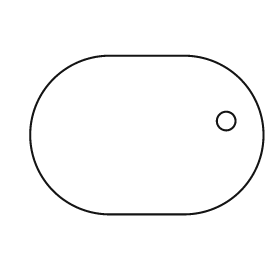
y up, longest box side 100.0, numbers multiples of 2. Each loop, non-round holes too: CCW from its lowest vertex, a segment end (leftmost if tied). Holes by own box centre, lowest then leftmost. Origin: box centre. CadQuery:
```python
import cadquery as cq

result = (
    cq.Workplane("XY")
    .moveTo(-16.0, -34.0)
    .lineTo(16.0, -34.0)
    .threePointArc((50.0, 0.0), (16.0, 34.0))
    .lineTo(-16.0, 34.0)
    .threePointArc((-50.0, 0.0), (-16.0, -34.0))
    .close()
    .moveTo(34.0, 6.0)
    .circle(4.0)
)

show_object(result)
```